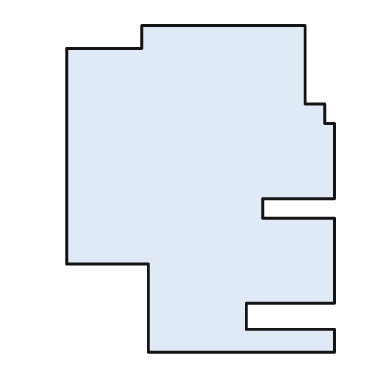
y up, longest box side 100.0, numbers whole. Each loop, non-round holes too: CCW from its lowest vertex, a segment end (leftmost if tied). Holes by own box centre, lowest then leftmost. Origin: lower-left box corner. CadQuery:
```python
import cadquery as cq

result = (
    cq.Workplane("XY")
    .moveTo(25.0, 0.0)
    .lineTo(82.0, 0.0)
    .lineTo(82.0, 7.0)
    .lineTo(55.0, 7.0)
    .lineTo(55.0, 15.0)
    .lineTo(82.0, 15.0)
    .lineTo(82.0, 41.0)
    .lineTo(60.0, 41.0)
    .lineTo(60.0, 47.0)
    .lineTo(82.0, 47.0)
    .lineTo(82.0, 70.0)
    .lineTo(79.0, 70.0)
    .lineTo(79.0, 76.0)
    .lineTo(73.0, 76.0)
    .lineTo(73.0, 100.0)
    .lineTo(23.0, 100.0)
    .lineTo(23.0, 93.0)
    .lineTo(0.0, 93.0)
    .lineTo(0.0, 27.0)
    .lineTo(25.0, 27.0)
    .close()
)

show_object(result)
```